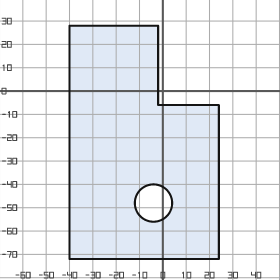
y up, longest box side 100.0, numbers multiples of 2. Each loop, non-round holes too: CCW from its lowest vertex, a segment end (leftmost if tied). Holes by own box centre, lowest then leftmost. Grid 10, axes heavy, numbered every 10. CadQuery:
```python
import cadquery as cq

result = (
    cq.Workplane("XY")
    .moveTo(-40.0, -72.0)
    .lineTo(24.0, -72.0)
    .lineTo(24.0, -6.0)
    .lineTo(-2.0, -6.0)
    .lineTo(-2.0, 28.0)
    .lineTo(-40.0, 28.0)
    .close()
    .moveTo(-4.0, -48.0)
    .circle(8.0)
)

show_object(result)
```